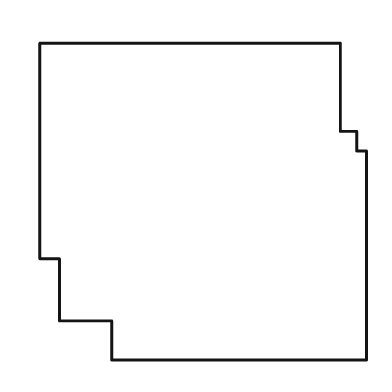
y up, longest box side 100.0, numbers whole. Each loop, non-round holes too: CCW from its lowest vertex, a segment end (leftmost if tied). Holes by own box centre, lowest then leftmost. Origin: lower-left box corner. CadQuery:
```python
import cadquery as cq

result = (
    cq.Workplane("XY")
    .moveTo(22.0, 0.0)
    .lineTo(100.0, 0.0)
    .lineTo(100.0, 64.0)
    .lineTo(97.0, 64.0)
    .lineTo(97.0, 70.0)
    .lineTo(92.0, 70.0)
    .lineTo(92.0, 97.0)
    .lineTo(0.0, 97.0)
    .lineTo(0.0, 31.0)
    .lineTo(6.0, 31.0)
    .lineTo(6.0, 12.0)
    .lineTo(22.0, 12.0)
    .close()
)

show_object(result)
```